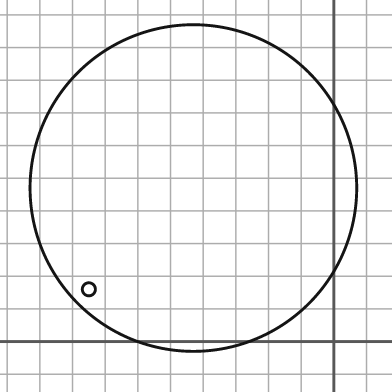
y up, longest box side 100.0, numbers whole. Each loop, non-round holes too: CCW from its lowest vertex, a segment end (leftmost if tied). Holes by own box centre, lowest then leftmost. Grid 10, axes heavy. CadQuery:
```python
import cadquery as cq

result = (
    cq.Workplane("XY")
    .moveTo(-43.0, 47.0)
    .circle(50.0)
    .moveTo(-75.0, 16.0)
    .circle(2.0)
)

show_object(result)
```